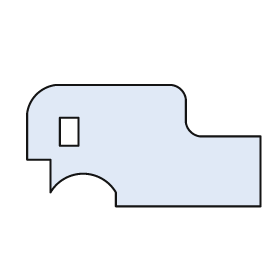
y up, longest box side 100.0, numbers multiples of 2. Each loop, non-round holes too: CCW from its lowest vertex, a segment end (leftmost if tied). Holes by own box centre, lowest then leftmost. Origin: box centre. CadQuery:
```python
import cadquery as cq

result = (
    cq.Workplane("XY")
    .moveTo(-12.0, -26.0)
    .lineTo(50.0, -26.0)
    .lineTo(50.0, 4.0)
    .lineTo(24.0, 4.0)
    .threePointArc((20.0, 6.0), (18.0, 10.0))
    .lineTo(18.0, 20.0)
    .threePointArc((16.0, 24.0), (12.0, 26.0))
    .lineTo(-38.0, 26.0)
    .threePointArc((-46.0, 22.0), (-50.0, 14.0))
    .lineTo(-50.0, -6.0)
    .lineTo(-40.0, -6.0)
    .lineTo(-40.0, -20.0)
    .threePointArc((-26.0, -12.0), (-12.0, -20.0))
    .close()
    .moveTo(-36.0, 0.0)
    .lineTo(-28.0, 0.0)
    .lineTo(-28.0, 12.0)
    .lineTo(-36.0, 12.0)
    .close()
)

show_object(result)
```